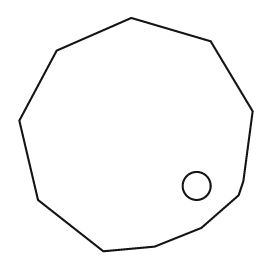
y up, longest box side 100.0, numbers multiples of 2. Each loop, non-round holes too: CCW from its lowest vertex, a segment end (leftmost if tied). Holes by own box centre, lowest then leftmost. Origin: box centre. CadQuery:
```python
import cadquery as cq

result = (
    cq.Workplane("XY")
    .moveTo(-14.0, -50.0)
    .lineTo(8.0, -48.0)
    .lineTo(28.0, -40.0)
    .lineTo(44.0, -26.0)
    .lineTo(46.0, -20.0)
    .lineTo(50.0, 10.0)
    .lineTo(32.0, 40.0)
    .lineTo(-2.0, 50.0)
    .lineTo(-34.0, 36.0)
    .lineTo(-50.0, 6.0)
    .lineTo(-42.0, -28.0)
    .close()
    .moveTo(26.0, -22.0)
    .circle(6.0)
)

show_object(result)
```